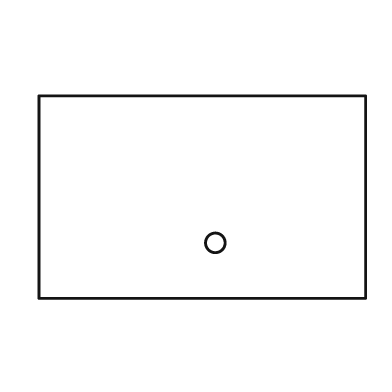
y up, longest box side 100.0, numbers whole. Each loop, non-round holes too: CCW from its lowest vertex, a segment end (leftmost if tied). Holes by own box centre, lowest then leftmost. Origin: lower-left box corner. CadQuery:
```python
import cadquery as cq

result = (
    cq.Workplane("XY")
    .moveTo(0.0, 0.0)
    .lineTo(100.0, 0.0)
    .lineTo(100.0, 62.0)
    .lineTo(0.0, 62.0)
    .close()
    .moveTo(54.0, 17.0)
    .circle(3.0)
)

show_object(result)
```